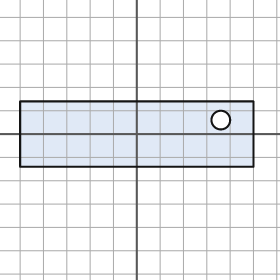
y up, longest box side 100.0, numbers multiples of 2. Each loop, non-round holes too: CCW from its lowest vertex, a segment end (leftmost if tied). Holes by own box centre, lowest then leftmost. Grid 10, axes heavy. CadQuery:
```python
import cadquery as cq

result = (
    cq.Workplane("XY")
    .moveTo(-50.0, -14.0)
    .lineTo(50.0, -14.0)
    .lineTo(50.0, 14.0)
    .lineTo(-50.0, 14.0)
    .close()
    .moveTo(36.0, 6.0)
    .circle(4.0)
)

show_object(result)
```